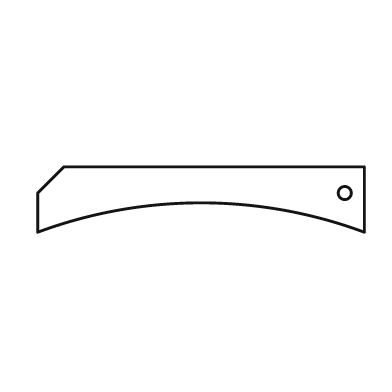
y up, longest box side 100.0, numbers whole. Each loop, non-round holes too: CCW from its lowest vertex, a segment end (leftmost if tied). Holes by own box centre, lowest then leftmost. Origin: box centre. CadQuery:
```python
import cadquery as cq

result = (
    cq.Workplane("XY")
    .moveTo(-50.0, -10.0)
    .threePointArc((0.0, -1.0), (50.0, -10.0))
    .lineTo(50.0, 10.0)
    .lineTo(-42.0, 10.0)
    .lineTo(-50.0, 2.0)
    .close()
    .moveTo(44.0, 2.0)
    .circle(2.0)
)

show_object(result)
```